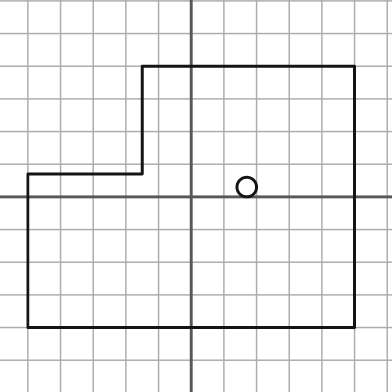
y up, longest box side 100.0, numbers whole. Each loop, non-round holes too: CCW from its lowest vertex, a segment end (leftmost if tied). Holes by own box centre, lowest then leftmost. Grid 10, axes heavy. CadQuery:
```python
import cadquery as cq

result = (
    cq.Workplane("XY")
    .moveTo(-50.0, -40.0)
    .lineTo(50.0, -40.0)
    .lineTo(50.0, 40.0)
    .lineTo(-15.0, 40.0)
    .lineTo(-15.0, 7.0)
    .lineTo(-50.0, 7.0)
    .close()
    .moveTo(17.0, 3.0)
    .circle(3.0)
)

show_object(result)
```